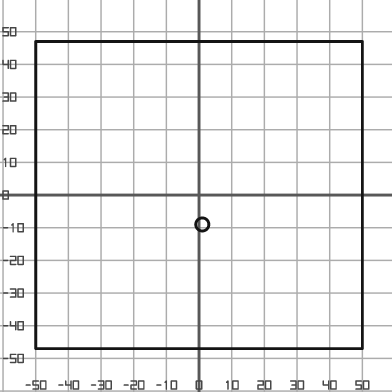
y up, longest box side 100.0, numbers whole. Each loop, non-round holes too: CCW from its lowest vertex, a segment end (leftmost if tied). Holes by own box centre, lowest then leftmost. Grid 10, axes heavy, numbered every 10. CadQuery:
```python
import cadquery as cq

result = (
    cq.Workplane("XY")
    .moveTo(-50.0, -47.0)
    .lineTo(50.0, -47.0)
    .lineTo(50.0, 47.0)
    .lineTo(-50.0, 47.0)
    .close()
    .moveTo(1.0, -9.0)
    .circle(2.0)
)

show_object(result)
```